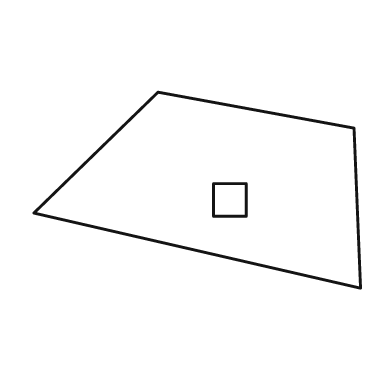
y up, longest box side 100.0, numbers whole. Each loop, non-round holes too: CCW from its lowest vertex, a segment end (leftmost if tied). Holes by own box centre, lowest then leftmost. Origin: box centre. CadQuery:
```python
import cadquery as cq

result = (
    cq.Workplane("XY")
    .moveTo(50.0, -30.0)
    .lineTo(48.0, 19.0)
    .lineTo(-12.0, 30.0)
    .lineTo(-50.0, -7.0)
    .close()
    .moveTo(5.0, -8.0)
    .lineTo(15.0, -8.0)
    .lineTo(15.0, 2.0)
    .lineTo(5.0, 2.0)
    .close()
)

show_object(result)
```